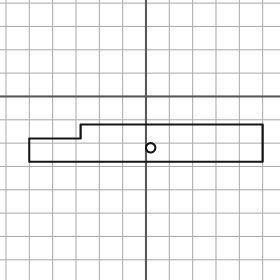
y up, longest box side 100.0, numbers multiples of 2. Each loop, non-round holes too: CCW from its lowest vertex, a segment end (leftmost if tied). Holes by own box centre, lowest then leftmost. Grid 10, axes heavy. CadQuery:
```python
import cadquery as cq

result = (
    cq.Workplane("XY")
    .moveTo(-50.0, -28.0)
    .lineTo(50.0, -28.0)
    .lineTo(50.0, -12.0)
    .lineTo(-28.0, -12.0)
    .lineTo(-28.0, -18.0)
    .lineTo(-50.0, -18.0)
    .close()
    .moveTo(2.0, -22.0)
    .circle(2.0)
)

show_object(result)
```